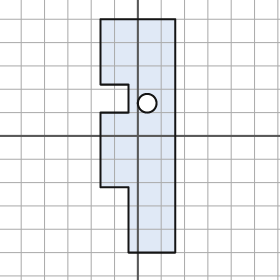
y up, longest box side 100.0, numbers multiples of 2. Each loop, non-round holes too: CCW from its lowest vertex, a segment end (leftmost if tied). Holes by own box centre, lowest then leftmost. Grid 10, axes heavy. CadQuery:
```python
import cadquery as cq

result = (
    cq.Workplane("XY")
    .moveTo(-4.0, -50.0)
    .lineTo(16.0, -50.0)
    .lineTo(16.0, 50.0)
    .lineTo(-16.0, 50.0)
    .lineTo(-16.0, 22.0)
    .lineTo(-4.0, 22.0)
    .lineTo(-4.0, 10.0)
    .lineTo(-16.0, 10.0)
    .lineTo(-16.0, -22.0)
    .lineTo(-4.0, -22.0)
    .close()
    .moveTo(4.0, 14.0)
    .circle(4.0)
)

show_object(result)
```